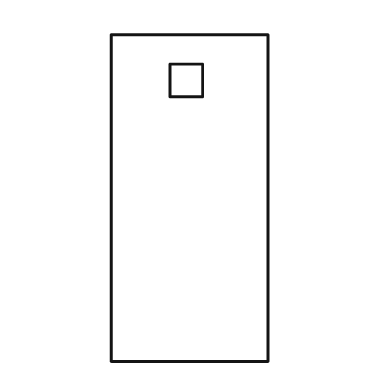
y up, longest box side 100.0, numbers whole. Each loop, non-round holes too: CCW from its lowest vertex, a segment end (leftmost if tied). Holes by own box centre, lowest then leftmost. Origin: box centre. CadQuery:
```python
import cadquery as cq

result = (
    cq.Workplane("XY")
    .moveTo(-24.0, -50.0)
    .lineTo(24.0, -50.0)
    .lineTo(24.0, 50.0)
    .lineTo(-24.0, 50.0)
    .close()
    .moveTo(-6.0, 31.0)
    .lineTo(4.0, 31.0)
    .lineTo(4.0, 41.0)
    .lineTo(-6.0, 41.0)
    .close()
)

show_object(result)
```